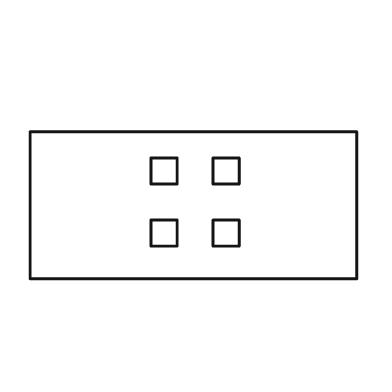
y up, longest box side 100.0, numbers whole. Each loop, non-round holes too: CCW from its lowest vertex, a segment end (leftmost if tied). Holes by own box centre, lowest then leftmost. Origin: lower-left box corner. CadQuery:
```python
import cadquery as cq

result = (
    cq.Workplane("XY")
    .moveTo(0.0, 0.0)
    .lineTo(100.0, 0.0)
    .lineTo(100.0, 45.0)
    .lineTo(0.0, 45.0)
    .close()
    .moveTo(37.0, 10.0)
    .lineTo(45.0, 10.0)
    .lineTo(45.0, 18.0)
    .lineTo(37.0, 18.0)
    .close()
    .moveTo(56.0, 10.0)
    .lineTo(64.0, 10.0)
    .lineTo(64.0, 18.0)
    .lineTo(56.0, 18.0)
    .close()
    .moveTo(37.0, 29.0)
    .lineTo(45.0, 29.0)
    .lineTo(45.0, 37.0)
    .lineTo(37.0, 37.0)
    .close()
    .moveTo(56.0, 29.0)
    .lineTo(64.0, 29.0)
    .lineTo(64.0, 37.0)
    .lineTo(56.0, 37.0)
    .close()
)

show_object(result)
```